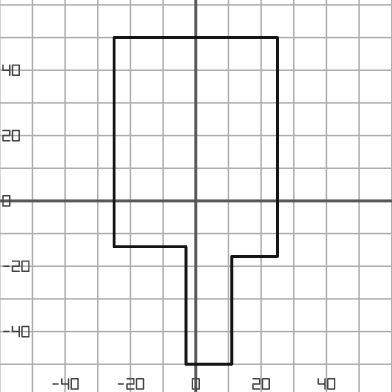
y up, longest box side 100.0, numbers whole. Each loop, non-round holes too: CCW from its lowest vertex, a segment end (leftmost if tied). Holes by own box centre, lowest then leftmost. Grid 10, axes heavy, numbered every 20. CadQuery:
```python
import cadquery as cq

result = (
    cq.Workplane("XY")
    .moveTo(-3.0, -50.0)
    .lineTo(11.0, -50.0)
    .lineTo(11.0, -17.0)
    .lineTo(25.0, -17.0)
    .lineTo(25.0, 50.0)
    .lineTo(-25.0, 50.0)
    .lineTo(-25.0, -14.0)
    .lineTo(-3.0, -14.0)
    .close()
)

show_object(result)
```